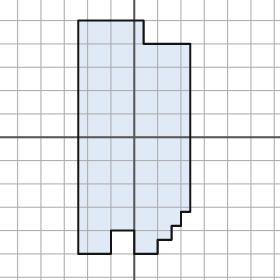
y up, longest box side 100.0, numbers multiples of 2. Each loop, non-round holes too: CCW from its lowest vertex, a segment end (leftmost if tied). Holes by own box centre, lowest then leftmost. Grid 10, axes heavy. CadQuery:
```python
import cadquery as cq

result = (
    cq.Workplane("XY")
    .moveTo(-24.0, -50.0)
    .lineTo(-10.0, -50.0)
    .lineTo(-10.0, -40.0)
    .lineTo(0.0, -40.0)
    .lineTo(0.0, -50.0)
    .lineTo(10.0, -50.0)
    .lineTo(10.0, -44.0)
    .lineTo(16.0, -44.0)
    .lineTo(16.0, -38.0)
    .lineTo(20.0, -38.0)
    .lineTo(20.0, -32.0)
    .lineTo(24.0, -32.0)
    .lineTo(24.0, 40.0)
    .lineTo(4.0, 40.0)
    .lineTo(4.0, 50.0)
    .lineTo(-24.0, 50.0)
    .close()
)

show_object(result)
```